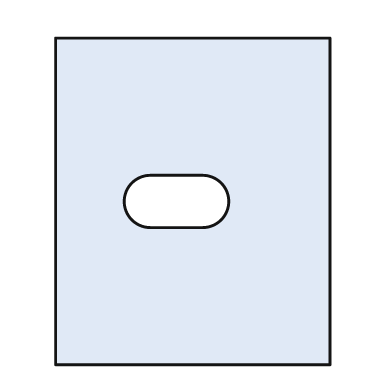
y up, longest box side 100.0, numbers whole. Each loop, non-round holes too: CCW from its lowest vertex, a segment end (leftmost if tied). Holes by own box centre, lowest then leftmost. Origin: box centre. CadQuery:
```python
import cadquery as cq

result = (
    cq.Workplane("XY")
    .moveTo(-42.0, -50.0)
    .lineTo(42.0, -50.0)
    .lineTo(42.0, 50.0)
    .lineTo(-42.0, 50.0)
    .close()
    .moveTo(-13.0, -8.0)
    .lineTo(3.0, -8.0)
    .threePointArc((11.0, 0.0), (3.0, 8.0))
    .lineTo(-13.0, 8.0)
    .threePointArc((-21.0, 0.0), (-13.0, -8.0))
    .close()
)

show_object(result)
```